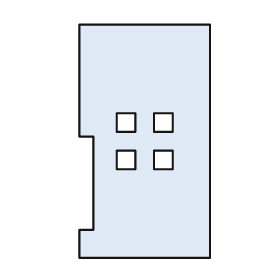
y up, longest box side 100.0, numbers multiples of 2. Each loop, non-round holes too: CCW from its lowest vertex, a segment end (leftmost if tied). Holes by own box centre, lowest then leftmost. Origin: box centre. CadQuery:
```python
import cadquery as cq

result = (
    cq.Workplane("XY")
    .moveTo(-28.0, -50.0)
    .lineTo(28.0, -50.0)
    .lineTo(28.0, 50.0)
    .lineTo(-28.0, 50.0)
    .lineTo(-28.0, 2.0)
    .lineTo(-22.0, 2.0)
    .lineTo(-22.0, -38.0)
    .lineTo(-28.0, -38.0)
    .close()
    .moveTo(-12.0, -12.0)
    .lineTo(-4.0, -12.0)
    .lineTo(-4.0, -4.0)
    .lineTo(-12.0, -4.0)
    .close()
    .moveTo(4.0, -12.0)
    .lineTo(12.0, -12.0)
    .lineTo(12.0, -4.0)
    .lineTo(4.0, -4.0)
    .close()
    .moveTo(-12.0, 4.0)
    .lineTo(-4.0, 4.0)
    .lineTo(-4.0, 12.0)
    .lineTo(-12.0, 12.0)
    .close()
    .moveTo(4.0, 4.0)
    .lineTo(12.0, 4.0)
    .lineTo(12.0, 12.0)
    .lineTo(4.0, 12.0)
    .close()
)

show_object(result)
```